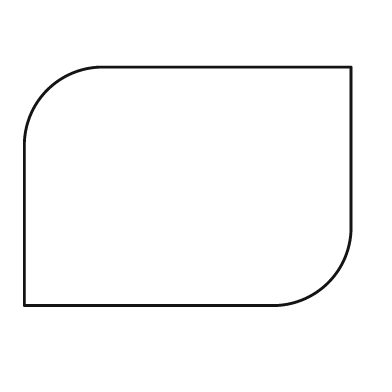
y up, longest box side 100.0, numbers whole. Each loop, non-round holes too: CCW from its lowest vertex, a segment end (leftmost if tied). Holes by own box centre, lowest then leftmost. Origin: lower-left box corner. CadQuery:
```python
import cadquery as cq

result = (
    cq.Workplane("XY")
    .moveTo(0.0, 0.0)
    .lineTo(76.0, 0.0)
    .threePointArc((93.0, 7.0), (100.0, 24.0))
    .lineTo(100.0, 73.0)
    .lineTo(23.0, 73.0)
    .threePointArc((7.0, 66.0), (0.0, 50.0))
    .close()
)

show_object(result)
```